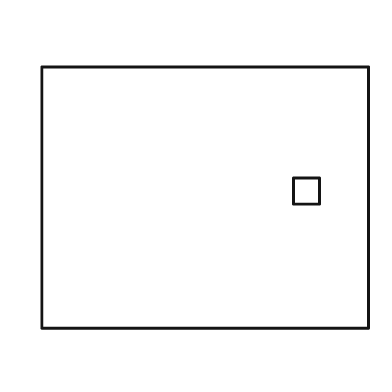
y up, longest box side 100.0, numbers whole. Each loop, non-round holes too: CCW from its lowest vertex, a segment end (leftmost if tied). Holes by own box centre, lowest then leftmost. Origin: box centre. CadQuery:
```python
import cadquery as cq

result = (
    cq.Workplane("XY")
    .moveTo(-50.0, -40.0)
    .lineTo(50.0, -40.0)
    .lineTo(50.0, 40.0)
    .lineTo(-50.0, 40.0)
    .close()
    .moveTo(27.0, -2.0)
    .lineTo(35.0, -2.0)
    .lineTo(35.0, 6.0)
    .lineTo(27.0, 6.0)
    .close()
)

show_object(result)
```